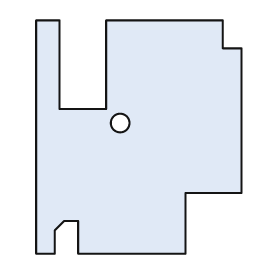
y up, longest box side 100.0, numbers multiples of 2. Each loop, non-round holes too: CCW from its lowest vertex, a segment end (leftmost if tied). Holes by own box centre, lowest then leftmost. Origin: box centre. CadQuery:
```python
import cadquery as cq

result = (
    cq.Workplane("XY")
    .moveTo(-44.0, -50.0)
    .lineTo(-36.0, -50.0)
    .lineTo(-36.0, -40.0)
    .lineTo(-32.0, -36.0)
    .lineTo(-26.0, -36.0)
    .lineTo(-26.0, -50.0)
    .lineTo(20.0, -50.0)
    .lineTo(20.0, -24.0)
    .lineTo(44.0, -24.0)
    .lineTo(44.0, 38.0)
    .lineTo(36.0, 38.0)
    .lineTo(36.0, 50.0)
    .lineTo(-14.0, 50.0)
    .lineTo(-14.0, 12.0)
    .lineTo(-34.0, 12.0)
    .lineTo(-34.0, 50.0)
    .lineTo(-44.0, 50.0)
    .close()
    .moveTo(-8.0, 6.0)
    .circle(4.0)
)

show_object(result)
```